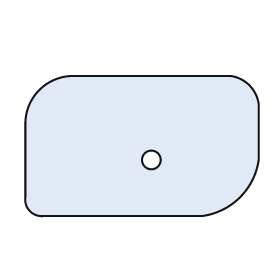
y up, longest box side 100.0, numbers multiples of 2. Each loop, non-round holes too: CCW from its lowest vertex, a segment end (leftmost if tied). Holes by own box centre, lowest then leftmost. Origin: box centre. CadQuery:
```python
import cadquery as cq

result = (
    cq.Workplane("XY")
    .moveTo(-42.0, -30.0)
    .lineTo(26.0, -30.0)
    .threePointArc((42.0, -22.0), (50.0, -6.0))
    .lineTo(50.0, 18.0)
    .threePointArc((46.0, 26.0), (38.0, 30.0))
    .lineTo(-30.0, 30.0)
    .threePointArc((-44.0, 24.0), (-50.0, 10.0))
    .lineTo(-50.0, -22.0)
    .threePointArc((-48.0, -28.0), (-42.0, -30.0))
    .close()
    .moveTo(4.0, -6.0)
    .circle(4.0)
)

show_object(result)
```